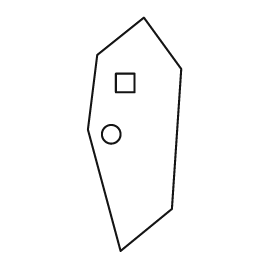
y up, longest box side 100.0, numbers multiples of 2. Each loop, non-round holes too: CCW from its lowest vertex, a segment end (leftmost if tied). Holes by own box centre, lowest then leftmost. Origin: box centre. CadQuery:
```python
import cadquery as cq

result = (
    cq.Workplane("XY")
    .moveTo(-6.0, -50.0)
    .lineTo(16.0, -32.0)
    .lineTo(20.0, 28.0)
    .lineTo(4.0, 50.0)
    .lineTo(-16.0, 34.0)
    .lineTo(-20.0, 2.0)
    .close()
    .moveTo(-10.0, 0.0)
    .circle(4.0)
    .moveTo(-8.0, 18.0)
    .lineTo(0.0, 18.0)
    .lineTo(0.0, 26.0)
    .lineTo(-8.0, 26.0)
    .close()
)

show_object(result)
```